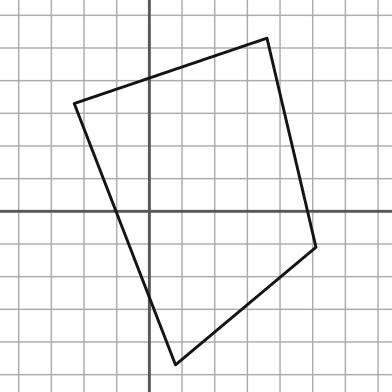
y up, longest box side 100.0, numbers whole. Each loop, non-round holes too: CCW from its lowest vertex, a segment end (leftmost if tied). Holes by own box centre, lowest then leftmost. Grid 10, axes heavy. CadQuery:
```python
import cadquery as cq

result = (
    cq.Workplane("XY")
    .moveTo(8.0, -47.0)
    .lineTo(51.0, -11.0)
    .lineTo(36.0, 53.0)
    .lineTo(-23.0, 33.0)
    .close()
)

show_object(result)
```